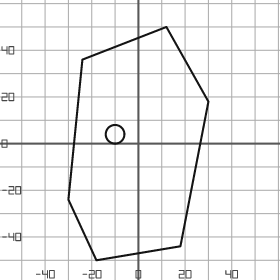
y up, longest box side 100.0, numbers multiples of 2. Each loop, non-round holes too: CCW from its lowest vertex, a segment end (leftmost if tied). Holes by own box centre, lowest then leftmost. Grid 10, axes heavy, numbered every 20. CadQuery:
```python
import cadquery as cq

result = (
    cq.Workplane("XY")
    .moveTo(-18.0, -50.0)
    .lineTo(18.0, -44.0)
    .lineTo(30.0, 18.0)
    .lineTo(12.0, 50.0)
    .lineTo(-24.0, 36.0)
    .lineTo(-30.0, -24.0)
    .close()
    .moveTo(-10.0, 4.0)
    .circle(4.0)
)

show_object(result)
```